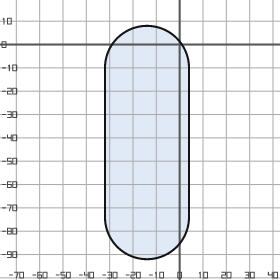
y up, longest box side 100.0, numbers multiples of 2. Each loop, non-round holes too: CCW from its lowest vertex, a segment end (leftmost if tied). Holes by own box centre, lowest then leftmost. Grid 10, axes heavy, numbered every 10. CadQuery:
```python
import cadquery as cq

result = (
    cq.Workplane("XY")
    .moveTo(-32.0, -74.0)
    .threePointArc((-14.0, -92.0), (4.0, -74.0))
    .lineTo(4.0, -10.0)
    .threePointArc((-14.0, 8.0), (-32.0, -10.0))
    .close()
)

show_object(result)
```